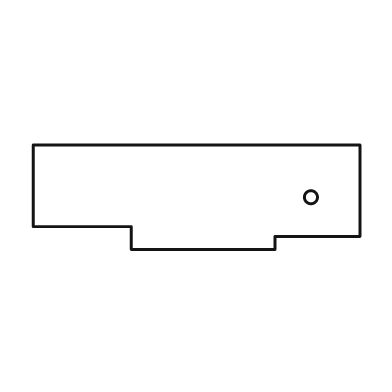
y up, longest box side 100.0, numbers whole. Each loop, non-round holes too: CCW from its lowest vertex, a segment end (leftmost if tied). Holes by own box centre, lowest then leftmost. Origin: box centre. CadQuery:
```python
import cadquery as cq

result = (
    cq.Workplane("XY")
    .moveTo(-20.0, -16.0)
    .lineTo(24.0, -16.0)
    .lineTo(24.0, -12.0)
    .lineTo(50.0, -12.0)
    .lineTo(50.0, 16.0)
    .lineTo(-50.0, 16.0)
    .lineTo(-50.0, -9.0)
    .lineTo(-20.0, -9.0)
    .close()
    .moveTo(35.0, 0.0)
    .circle(2.0)
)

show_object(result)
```